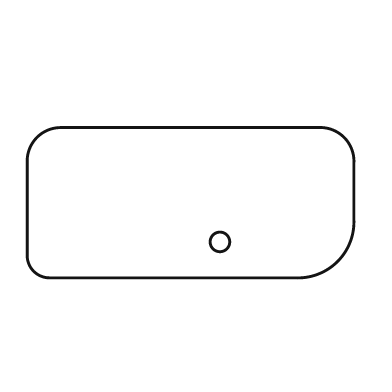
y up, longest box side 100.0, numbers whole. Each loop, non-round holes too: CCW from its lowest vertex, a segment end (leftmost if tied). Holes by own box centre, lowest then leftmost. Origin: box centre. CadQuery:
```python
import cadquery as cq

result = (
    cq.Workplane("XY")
    .moveTo(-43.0, -23.0)
    .lineTo(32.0, -23.0)
    .threePointArc((45.0, -18.0), (50.0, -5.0))
    .lineTo(50.0, 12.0)
    .threePointArc((47.0, 20.0), (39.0, 23.0))
    .lineTo(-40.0, 23.0)
    .threePointArc((-47.0, 20.0), (-50.0, 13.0))
    .lineTo(-50.0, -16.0)
    .threePointArc((-48.0, -21.0), (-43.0, -23.0))
    .close()
    .moveTo(9.0, -12.0)
    .circle(3.0)
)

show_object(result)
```